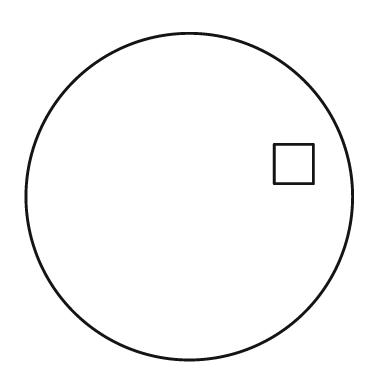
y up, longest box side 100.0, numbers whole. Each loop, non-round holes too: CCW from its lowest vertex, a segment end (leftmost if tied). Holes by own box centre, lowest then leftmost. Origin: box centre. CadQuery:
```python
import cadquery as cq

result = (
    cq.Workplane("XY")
    .moveTo(0.0, 0.0)
    .circle(50.0)
    .moveTo(26.0, 4.0)
    .lineTo(38.0, 4.0)
    .lineTo(38.0, 16.0)
    .lineTo(26.0, 16.0)
    .close()
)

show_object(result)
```